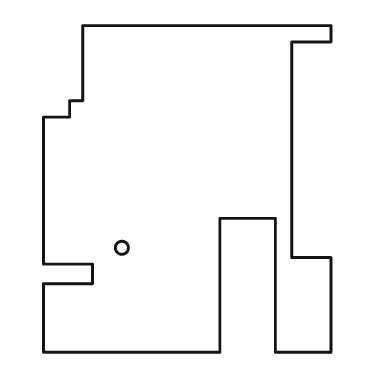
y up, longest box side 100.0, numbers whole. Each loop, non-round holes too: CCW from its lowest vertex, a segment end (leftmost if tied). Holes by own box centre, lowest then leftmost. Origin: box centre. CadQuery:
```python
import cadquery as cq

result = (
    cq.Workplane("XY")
    .moveTo(-44.0, -50.0)
    .lineTo(10.0, -50.0)
    .lineTo(10.0, -9.0)
    .lineTo(27.0, -9.0)
    .lineTo(27.0, -50.0)
    .lineTo(44.0, -50.0)
    .lineTo(44.0, -21.0)
    .lineTo(32.0, -21.0)
    .lineTo(32.0, 45.0)
    .lineTo(44.0, 45.0)
    .lineTo(44.0, 50.0)
    .lineTo(-32.0, 50.0)
    .lineTo(-32.0, 27.0)
    .lineTo(-36.0, 27.0)
    .lineTo(-36.0, 22.0)
    .lineTo(-44.0, 22.0)
    .lineTo(-44.0, -23.0)
    .lineTo(-29.0, -23.0)
    .lineTo(-29.0, -29.0)
    .lineTo(-44.0, -29.0)
    .close()
    .moveTo(-20.0, -18.0)
    .circle(2.0)
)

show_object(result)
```